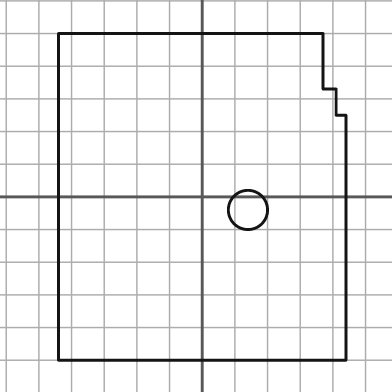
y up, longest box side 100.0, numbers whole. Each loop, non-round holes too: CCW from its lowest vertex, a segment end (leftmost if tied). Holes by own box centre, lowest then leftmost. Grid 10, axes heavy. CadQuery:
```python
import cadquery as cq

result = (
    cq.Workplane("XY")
    .moveTo(-44.0, -50.0)
    .lineTo(44.0, -50.0)
    .lineTo(44.0, 25.0)
    .lineTo(41.0, 25.0)
    .lineTo(41.0, 33.0)
    .lineTo(37.0, 33.0)
    .lineTo(37.0, 50.0)
    .lineTo(-44.0, 50.0)
    .close()
    .moveTo(14.0, -4.0)
    .circle(6.0)
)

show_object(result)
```